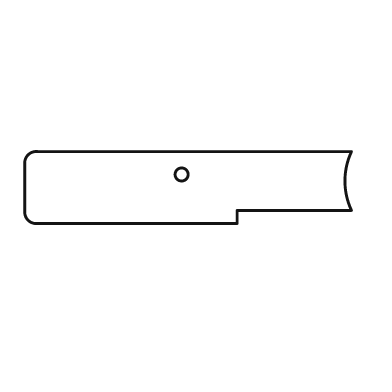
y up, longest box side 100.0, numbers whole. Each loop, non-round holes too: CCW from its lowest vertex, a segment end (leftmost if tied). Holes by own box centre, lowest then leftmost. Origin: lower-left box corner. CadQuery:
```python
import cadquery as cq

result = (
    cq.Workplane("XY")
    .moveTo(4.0, 0.0)
    .lineTo(65.0, 0.0)
    .lineTo(65.0, 4.0)
    .lineTo(100.0, 4.0)
    .threePointArc((98.0, 13.0), (100.0, 22.0))
    .lineTo(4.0, 22.0)
    .threePointArc((1.0, 21.0), (0.0, 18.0))
    .lineTo(0.0, 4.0)
    .threePointArc((1.0, 1.0), (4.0, 0.0))
    .close()
    .moveTo(48.0, 15.0)
    .circle(2.0)
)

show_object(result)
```